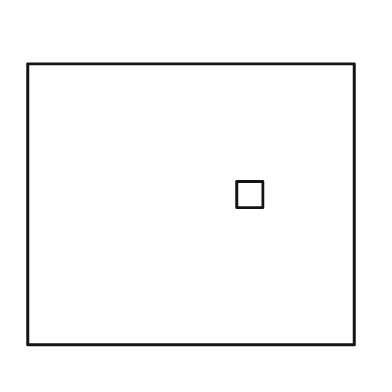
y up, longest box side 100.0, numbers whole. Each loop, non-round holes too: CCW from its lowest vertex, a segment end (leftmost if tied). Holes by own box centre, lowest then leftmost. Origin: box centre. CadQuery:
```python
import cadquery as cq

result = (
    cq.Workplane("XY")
    .moveTo(-50.0, -43.0)
    .lineTo(50.0, -43.0)
    .lineTo(50.0, 43.0)
    .lineTo(-50.0, 43.0)
    .close()
    .moveTo(14.0, -1.0)
    .lineTo(22.0, -1.0)
    .lineTo(22.0, 7.0)
    .lineTo(14.0, 7.0)
    .close()
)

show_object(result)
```